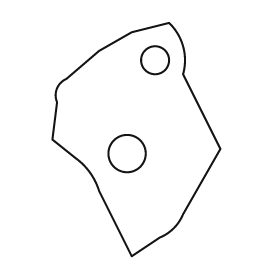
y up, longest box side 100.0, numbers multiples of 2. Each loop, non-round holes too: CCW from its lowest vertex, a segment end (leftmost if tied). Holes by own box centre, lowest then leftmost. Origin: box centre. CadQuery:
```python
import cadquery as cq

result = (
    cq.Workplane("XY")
    .moveTo(-2.0, -50.0)
    .lineTo(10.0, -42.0)
    .threePointArc((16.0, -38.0), (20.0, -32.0))
    .lineTo(36.0, -4.0)
    .lineTo(20.0, 28.0)
    .threePointArc((20.0, 40.0), (14.0, 50.0))
    .lineTo(-2.0, 46.0)
    .lineTo(-16.0, 38.0)
    .lineTo(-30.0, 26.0)
    .threePointArc((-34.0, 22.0), (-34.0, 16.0))
    .lineTo(-36.0, 0.0)
    .lineTo(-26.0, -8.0)
    .threePointArc((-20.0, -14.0), (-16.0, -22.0))
    .close()
    .moveTo(-4.0, -6.0)
    .circle(8.0)
    .moveTo(8.0, 34.0)
    .circle(6.0)
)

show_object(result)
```